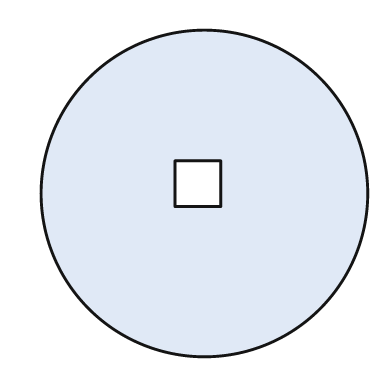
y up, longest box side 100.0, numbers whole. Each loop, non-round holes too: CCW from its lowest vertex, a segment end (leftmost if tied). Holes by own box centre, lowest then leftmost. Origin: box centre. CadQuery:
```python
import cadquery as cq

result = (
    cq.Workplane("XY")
    .moveTo(0.0, 0.0)
    .circle(50.0)
    .moveTo(-9.0, -4.0)
    .lineTo(5.0, -4.0)
    .lineTo(5.0, 10.0)
    .lineTo(-9.0, 10.0)
    .close()
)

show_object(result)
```